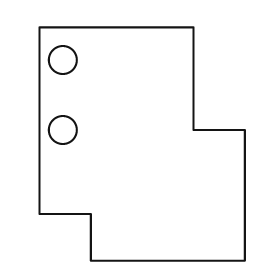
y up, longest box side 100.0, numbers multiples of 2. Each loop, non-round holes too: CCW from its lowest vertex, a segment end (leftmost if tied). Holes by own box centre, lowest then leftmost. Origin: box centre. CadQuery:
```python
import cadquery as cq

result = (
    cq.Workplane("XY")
    .moveTo(-22.0, -50.0)
    .lineTo(44.0, -50.0)
    .lineTo(44.0, 6.0)
    .lineTo(22.0, 6.0)
    .lineTo(22.0, 50.0)
    .lineTo(-44.0, 50.0)
    .lineTo(-44.0, -30.0)
    .lineTo(-22.0, -30.0)
    .close()
    .moveTo(-34.0, 6.0)
    .circle(6.0)
    .moveTo(-34.0, 36.0)
    .circle(6.0)
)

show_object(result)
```